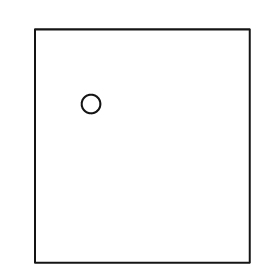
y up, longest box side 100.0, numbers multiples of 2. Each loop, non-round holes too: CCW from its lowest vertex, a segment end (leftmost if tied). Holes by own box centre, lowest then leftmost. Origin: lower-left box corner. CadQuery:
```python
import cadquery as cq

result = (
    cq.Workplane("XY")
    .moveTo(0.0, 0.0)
    .lineTo(92.0, 0.0)
    .lineTo(92.0, 100.0)
    .lineTo(0.0, 100.0)
    .close()
    .moveTo(24.0, 68.0)
    .circle(4.0)
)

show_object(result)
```